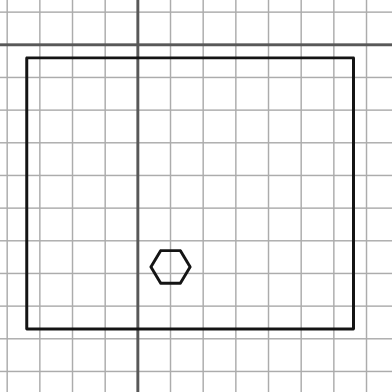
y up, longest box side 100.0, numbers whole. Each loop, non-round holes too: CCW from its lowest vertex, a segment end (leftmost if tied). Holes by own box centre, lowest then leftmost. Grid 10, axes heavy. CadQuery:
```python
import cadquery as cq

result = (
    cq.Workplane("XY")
    .moveTo(-34.0, -87.0)
    .lineTo(66.0, -87.0)
    .lineTo(66.0, -4.0)
    .lineTo(-34.0, -4.0)
    .close()
    .moveTo(7.0, -73.0)
    .lineTo(13.0, -73.0)
    .lineTo(16.0, -68.0)
    .lineTo(13.0, -63.0)
    .lineTo(7.0, -63.0)
    .lineTo(4.0, -68.0)
    .close()
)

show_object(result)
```